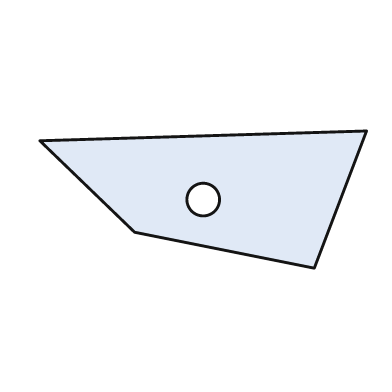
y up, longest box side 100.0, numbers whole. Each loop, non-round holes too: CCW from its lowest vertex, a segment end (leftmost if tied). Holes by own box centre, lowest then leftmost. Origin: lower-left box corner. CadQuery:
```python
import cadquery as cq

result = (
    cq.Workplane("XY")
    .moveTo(84.0, 0.0)
    .lineTo(100.0, 42.0)
    .lineTo(0.0, 39.0)
    .lineTo(29.0, 11.0)
    .close()
    .moveTo(50.0, 21.0)
    .circle(5.0)
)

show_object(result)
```